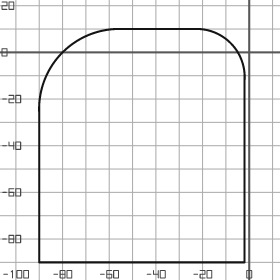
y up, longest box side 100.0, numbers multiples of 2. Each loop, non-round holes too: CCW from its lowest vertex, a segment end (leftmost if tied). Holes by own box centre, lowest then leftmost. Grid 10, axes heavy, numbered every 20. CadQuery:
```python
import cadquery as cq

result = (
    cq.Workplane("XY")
    .moveTo(-90.0, -90.0)
    .lineTo(-2.0, -90.0)
    .lineTo(-2.0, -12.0)
    .threePointArc((-8.0, 4.0), (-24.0, 10.0))
    .lineTo(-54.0, 10.0)
    .threePointArc((-80.0, 0.0), (-90.0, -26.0))
    .close()
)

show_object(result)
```